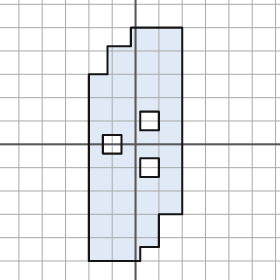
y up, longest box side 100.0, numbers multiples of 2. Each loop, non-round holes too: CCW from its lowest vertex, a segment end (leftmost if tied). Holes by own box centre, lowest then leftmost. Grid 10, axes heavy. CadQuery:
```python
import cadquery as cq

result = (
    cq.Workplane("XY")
    .moveTo(-20.0, -50.0)
    .lineTo(2.0, -50.0)
    .lineTo(2.0, -44.0)
    .lineTo(10.0, -44.0)
    .lineTo(10.0, -30.0)
    .lineTo(20.0, -30.0)
    .lineTo(20.0, 50.0)
    .lineTo(-2.0, 50.0)
    .lineTo(-2.0, 42.0)
    .lineTo(-12.0, 42.0)
    .lineTo(-12.0, 30.0)
    .lineTo(-20.0, 30.0)
    .close()
    .moveTo(2.0, -14.0)
    .lineTo(10.0, -14.0)
    .lineTo(10.0, -6.0)
    .lineTo(2.0, -6.0)
    .close()
    .moveTo(-14.0, -4.0)
    .lineTo(-6.0, -4.0)
    .lineTo(-6.0, 4.0)
    .lineTo(-14.0, 4.0)
    .close()
    .moveTo(2.0, 6.0)
    .lineTo(10.0, 6.0)
    .lineTo(10.0, 14.0)
    .lineTo(2.0, 14.0)
    .close()
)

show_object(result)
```